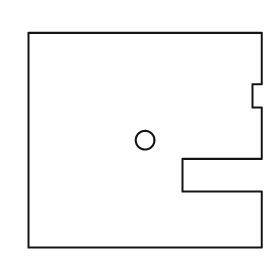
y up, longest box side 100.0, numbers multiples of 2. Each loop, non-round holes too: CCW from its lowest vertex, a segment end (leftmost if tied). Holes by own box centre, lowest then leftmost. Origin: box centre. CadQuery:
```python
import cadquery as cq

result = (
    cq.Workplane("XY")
    .moveTo(-50.0, -46.0)
    .lineTo(50.0, -46.0)
    .lineTo(50.0, -22.0)
    .lineTo(16.0, -22.0)
    .lineTo(16.0, -8.0)
    .lineTo(50.0, -8.0)
    .lineTo(50.0, 14.0)
    .lineTo(46.0, 14.0)
    .lineTo(46.0, 24.0)
    .lineTo(50.0, 24.0)
    .lineTo(50.0, 46.0)
    .lineTo(-50.0, 46.0)
    .close()
    .moveTo(0.0, 0.0)
    .circle(4.0)
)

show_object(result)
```